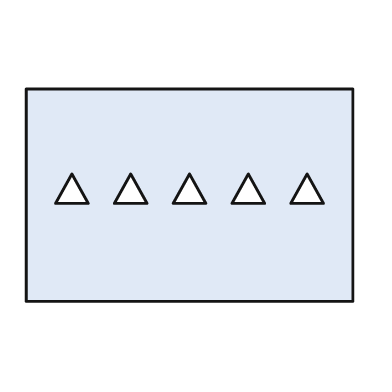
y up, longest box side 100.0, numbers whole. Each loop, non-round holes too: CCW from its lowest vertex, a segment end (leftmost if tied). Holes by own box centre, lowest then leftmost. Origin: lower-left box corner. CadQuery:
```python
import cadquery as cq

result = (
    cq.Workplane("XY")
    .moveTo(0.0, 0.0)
    .lineTo(100.0, 0.0)
    .lineTo(100.0, 65.0)
    .lineTo(0.0, 65.0)
    .close()
    .moveTo(9.0, 30.0)
    .lineTo(19.0, 30.0)
    .lineTo(14.0, 39.0)
    .close()
    .moveTo(27.0, 30.0)
    .lineTo(37.0, 30.0)
    .lineTo(32.0, 39.0)
    .close()
    .moveTo(45.0, 30.0)
    .lineTo(55.0, 30.0)
    .lineTo(50.0, 39.0)
    .close()
    .moveTo(63.0, 30.0)
    .lineTo(73.0, 30.0)
    .lineTo(68.0, 39.0)
    .close()
    .moveTo(81.0, 30.0)
    .lineTo(91.0, 30.0)
    .lineTo(86.0, 39.0)
    .close()
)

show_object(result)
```